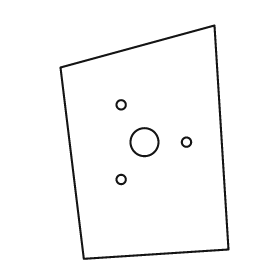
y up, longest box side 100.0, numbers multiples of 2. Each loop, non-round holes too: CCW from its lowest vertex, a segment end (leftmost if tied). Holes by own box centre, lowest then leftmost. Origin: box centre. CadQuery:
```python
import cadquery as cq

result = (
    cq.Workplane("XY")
    .moveTo(-26.0, -50.0)
    .lineTo(36.0, -46.0)
    .lineTo(30.0, 50.0)
    .lineTo(-36.0, 32.0)
    .close()
    .moveTo(-10.0, -16.0)
    .circle(2.0)
    .moveTo(0.0, 0.0)
    .circle(6.0)
    .moveTo(18.0, 0.0)
    .circle(2.0)
    .moveTo(-10.0, 16.0)
    .circle(2.0)
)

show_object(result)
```